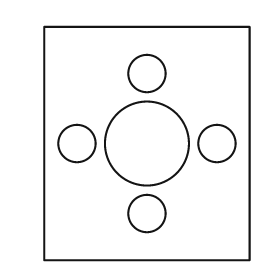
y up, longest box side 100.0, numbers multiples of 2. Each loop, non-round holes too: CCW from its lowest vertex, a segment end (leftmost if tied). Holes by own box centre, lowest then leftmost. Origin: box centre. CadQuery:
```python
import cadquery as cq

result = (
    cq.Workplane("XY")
    .moveTo(-44.0, -50.0)
    .lineTo(44.0, -50.0)
    .lineTo(44.0, 50.0)
    .lineTo(-44.0, 50.0)
    .close()
    .moveTo(0.0, -30.0)
    .circle(8.0)
    .moveTo(-30.0, 0.0)
    .circle(8.0)
    .moveTo(0.0, 0.0)
    .circle(18.0)
    .moveTo(30.0, 0.0)
    .circle(8.0)
    .moveTo(0.0, 30.0)
    .circle(8.0)
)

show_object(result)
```